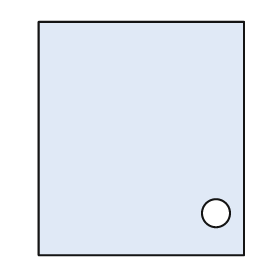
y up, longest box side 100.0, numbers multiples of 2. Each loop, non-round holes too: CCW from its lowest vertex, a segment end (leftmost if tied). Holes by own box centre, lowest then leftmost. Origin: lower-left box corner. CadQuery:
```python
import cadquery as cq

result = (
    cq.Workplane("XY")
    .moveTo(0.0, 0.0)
    .lineTo(88.0, 0.0)
    .lineTo(88.0, 100.0)
    .lineTo(0.0, 100.0)
    .close()
    .moveTo(76.0, 18.0)
    .circle(6.0)
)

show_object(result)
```